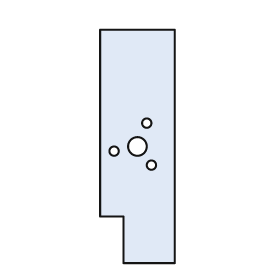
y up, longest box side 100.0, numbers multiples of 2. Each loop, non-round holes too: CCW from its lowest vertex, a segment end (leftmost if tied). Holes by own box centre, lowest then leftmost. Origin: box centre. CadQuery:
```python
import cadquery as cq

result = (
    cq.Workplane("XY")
    .moveTo(-6.0, -50.0)
    .lineTo(16.0, -50.0)
    .lineTo(16.0, 50.0)
    .lineTo(-16.0, 50.0)
    .lineTo(-16.0, -30.0)
    .lineTo(-6.0, -30.0)
    .close()
    .moveTo(6.0, -8.0)
    .circle(2.0)
    .moveTo(-10.0, -2.0)
    .circle(2.0)
    .moveTo(0.0, 0.0)
    .circle(4.0)
    .moveTo(4.0, 10.0)
    .circle(2.0)
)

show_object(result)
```